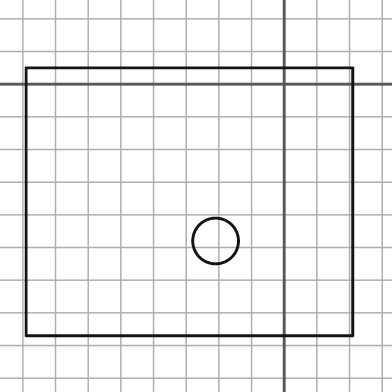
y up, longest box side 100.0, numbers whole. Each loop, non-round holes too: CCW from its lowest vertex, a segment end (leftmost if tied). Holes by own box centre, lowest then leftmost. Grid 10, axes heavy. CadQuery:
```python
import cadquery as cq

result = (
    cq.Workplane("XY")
    .moveTo(-79.0, -77.0)
    .lineTo(21.0, -77.0)
    .lineTo(21.0, 5.0)
    .lineTo(-79.0, 5.0)
    .close()
    .moveTo(-21.0, -48.0)
    .circle(7.0)
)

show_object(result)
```